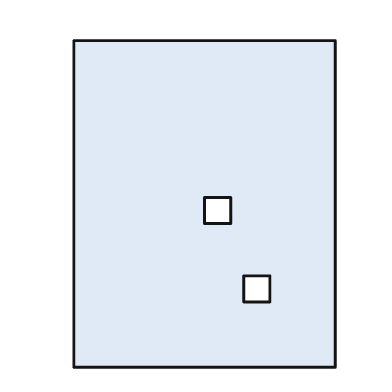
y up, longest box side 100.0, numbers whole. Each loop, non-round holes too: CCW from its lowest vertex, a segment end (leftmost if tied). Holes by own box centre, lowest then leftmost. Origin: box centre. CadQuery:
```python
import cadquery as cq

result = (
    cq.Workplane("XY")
    .moveTo(-40.0, -50.0)
    .lineTo(40.0, -50.0)
    .lineTo(40.0, 50.0)
    .lineTo(-40.0, 50.0)
    .close()
    .moveTo(12.0, -30.0)
    .lineTo(20.0, -30.0)
    .lineTo(20.0, -22.0)
    .lineTo(12.0, -22.0)
    .close()
    .moveTo(0.0, -6.0)
    .lineTo(8.0, -6.0)
    .lineTo(8.0, 2.0)
    .lineTo(0.0, 2.0)
    .close()
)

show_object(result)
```